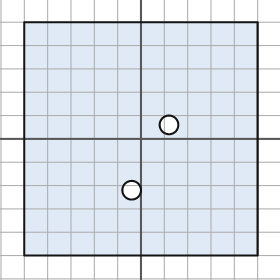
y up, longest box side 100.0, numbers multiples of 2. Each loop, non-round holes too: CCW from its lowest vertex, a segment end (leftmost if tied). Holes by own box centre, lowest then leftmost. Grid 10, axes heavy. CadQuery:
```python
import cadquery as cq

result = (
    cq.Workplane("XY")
    .moveTo(-50.0, -50.0)
    .lineTo(50.0, -50.0)
    .lineTo(50.0, 50.0)
    .lineTo(-50.0, 50.0)
    .close()
    .moveTo(-4.0, -22.0)
    .circle(4.0)
    .moveTo(12.0, 6.0)
    .circle(4.0)
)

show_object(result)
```